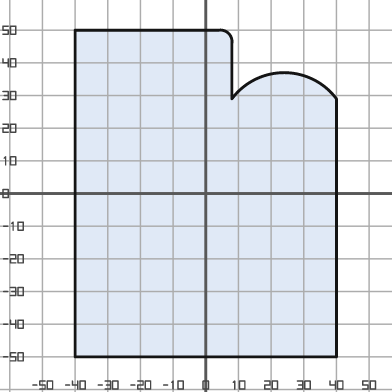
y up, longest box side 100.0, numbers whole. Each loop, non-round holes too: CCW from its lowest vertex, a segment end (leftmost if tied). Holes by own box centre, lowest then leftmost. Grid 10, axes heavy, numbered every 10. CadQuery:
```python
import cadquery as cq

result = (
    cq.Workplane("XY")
    .moveTo(-40.0, -50.0)
    .lineTo(40.0, -50.0)
    .lineTo(40.0, 29.0)
    .threePointArc((24.0, 37.0), (8.0, 29.0))
    .lineTo(8.0, 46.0)
    .threePointArc((7.0, 49.0), (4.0, 50.0))
    .lineTo(-40.0, 50.0)
    .close()
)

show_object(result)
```